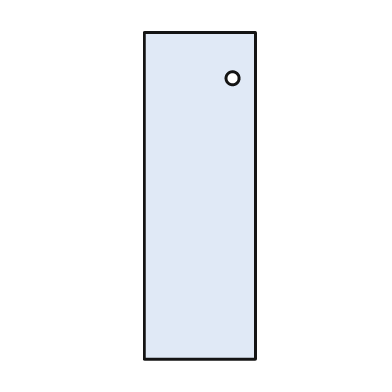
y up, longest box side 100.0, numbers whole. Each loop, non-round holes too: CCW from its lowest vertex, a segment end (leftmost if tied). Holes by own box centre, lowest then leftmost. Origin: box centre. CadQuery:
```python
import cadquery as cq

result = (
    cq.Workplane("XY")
    .moveTo(-17.0, -50.0)
    .lineTo(17.0, -50.0)
    .lineTo(17.0, 50.0)
    .lineTo(-17.0, 50.0)
    .close()
    .moveTo(10.0, 36.0)
    .circle(2.0)
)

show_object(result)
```